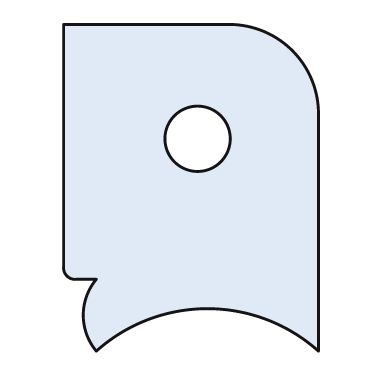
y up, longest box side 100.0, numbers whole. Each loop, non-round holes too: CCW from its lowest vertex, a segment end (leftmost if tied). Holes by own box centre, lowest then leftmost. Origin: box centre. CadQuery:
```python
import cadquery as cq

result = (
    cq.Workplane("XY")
    .moveTo(-29.0, -50.0)
    .threePointArc((5.0, -37.0), (39.0, -50.0))
    .lineTo(39.0, 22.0)
    .threePointArc((31.0, 42.0), (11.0, 50.0))
    .lineTo(-39.0, 50.0)
    .lineTo(-39.0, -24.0)
    .threePointArc((-38.0, -27.0), (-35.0, -28.0))
    .lineTo(-29.0, -28.0)
    .threePointArc((-33.0, -39.0), (-29.0, -50.0))
    .close()
    .moveTo(2.0, 15.0)
    .circle(10.0)
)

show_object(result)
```